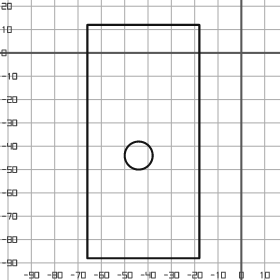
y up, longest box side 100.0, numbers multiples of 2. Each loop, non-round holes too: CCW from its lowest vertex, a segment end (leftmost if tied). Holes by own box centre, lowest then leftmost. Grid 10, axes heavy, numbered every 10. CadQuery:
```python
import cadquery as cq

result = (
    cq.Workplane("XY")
    .moveTo(-66.0, -88.0)
    .lineTo(-18.0, -88.0)
    .lineTo(-18.0, 12.0)
    .lineTo(-66.0, 12.0)
    .close()
    .moveTo(-44.0, -44.0)
    .circle(6.0)
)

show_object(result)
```